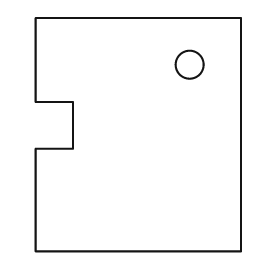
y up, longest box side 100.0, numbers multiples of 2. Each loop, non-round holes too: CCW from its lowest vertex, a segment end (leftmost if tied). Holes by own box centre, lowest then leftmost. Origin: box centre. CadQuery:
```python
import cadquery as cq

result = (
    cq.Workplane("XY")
    .moveTo(-44.0, -50.0)
    .lineTo(44.0, -50.0)
    .lineTo(44.0, 50.0)
    .lineTo(-44.0, 50.0)
    .lineTo(-44.0, 14.0)
    .lineTo(-28.0, 14.0)
    .lineTo(-28.0, -6.0)
    .lineTo(-44.0, -6.0)
    .close()
    .moveTo(22.0, 30.0)
    .circle(6.0)
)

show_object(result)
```